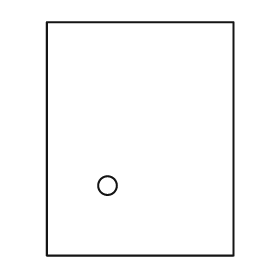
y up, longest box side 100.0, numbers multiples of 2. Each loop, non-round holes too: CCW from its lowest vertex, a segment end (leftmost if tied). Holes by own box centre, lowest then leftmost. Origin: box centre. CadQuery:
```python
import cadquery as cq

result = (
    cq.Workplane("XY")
    .moveTo(-40.0, -50.0)
    .lineTo(40.0, -50.0)
    .lineTo(40.0, 50.0)
    .lineTo(-40.0, 50.0)
    .close()
    .moveTo(-14.0, -20.0)
    .circle(4.0)
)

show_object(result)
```